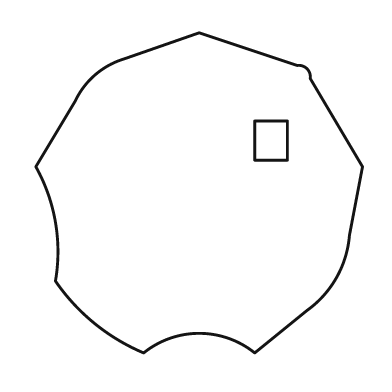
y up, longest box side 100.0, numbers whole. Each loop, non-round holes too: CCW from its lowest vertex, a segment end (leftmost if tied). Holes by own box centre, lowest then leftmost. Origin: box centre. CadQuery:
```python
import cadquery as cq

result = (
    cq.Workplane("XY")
    .moveTo(-17.0, -49.0)
    .threePointArc((0.0, -43.0), (17.0, -49.0))
    .lineTo(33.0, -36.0)
    .threePointArc((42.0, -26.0), (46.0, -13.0))
    .lineTo(50.0, 8.0)
    .lineTo(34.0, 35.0)
    .threePointArc((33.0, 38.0), (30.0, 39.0))
    .lineTo(0.0, 49.0)
    .lineTo(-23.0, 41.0)
    .threePointArc((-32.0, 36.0), (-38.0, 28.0))
    .lineTo(-50.0, 8.0)
    .threePointArc((-44.0, -9.0), (-44.0, -27.0))
    .threePointArc((-32.0, -40.0), (-17.0, -49.0))
    .close()
    .moveTo(17.0, 10.0)
    .lineTo(27.0, 10.0)
    .lineTo(27.0, 22.0)
    .lineTo(17.0, 22.0)
    .close()
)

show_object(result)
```